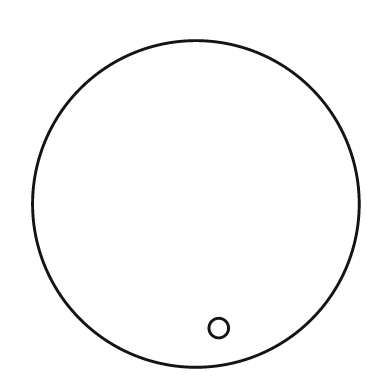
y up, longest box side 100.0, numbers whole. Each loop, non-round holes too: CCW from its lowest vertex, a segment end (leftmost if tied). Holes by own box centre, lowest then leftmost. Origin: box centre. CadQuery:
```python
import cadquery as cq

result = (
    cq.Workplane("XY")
    .moveTo(0.0, 0.0)
    .circle(50.0)
    .moveTo(7.0, -38.0)
    .circle(3.0)
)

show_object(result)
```